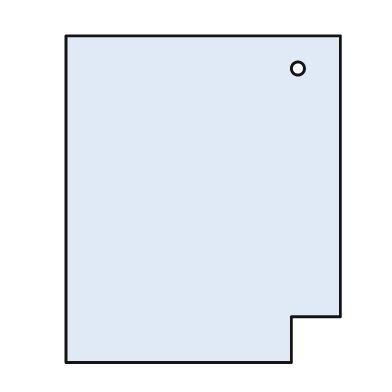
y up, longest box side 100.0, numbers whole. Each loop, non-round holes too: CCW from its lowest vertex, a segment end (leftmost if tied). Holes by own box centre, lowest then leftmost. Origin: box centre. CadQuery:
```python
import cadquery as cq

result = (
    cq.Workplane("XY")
    .moveTo(-42.0, -50.0)
    .lineTo(27.0, -50.0)
    .lineTo(27.0, -36.0)
    .lineTo(42.0, -36.0)
    .lineTo(42.0, 50.0)
    .lineTo(-42.0, 50.0)
    .close()
    .moveTo(29.0, 40.0)
    .circle(2.0)
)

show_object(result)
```